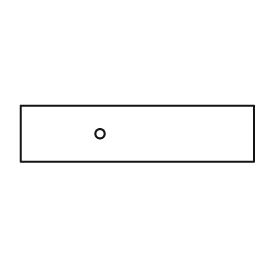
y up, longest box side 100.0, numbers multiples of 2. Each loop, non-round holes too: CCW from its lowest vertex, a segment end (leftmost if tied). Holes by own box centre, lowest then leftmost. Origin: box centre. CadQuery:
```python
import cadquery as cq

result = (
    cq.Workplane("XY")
    .moveTo(-50.0, -12.0)
    .lineTo(50.0, -12.0)
    .lineTo(50.0, 12.0)
    .lineTo(-50.0, 12.0)
    .close()
    .moveTo(-16.0, 0.0)
    .circle(2.0)
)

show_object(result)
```